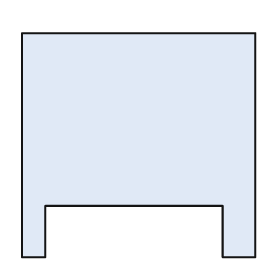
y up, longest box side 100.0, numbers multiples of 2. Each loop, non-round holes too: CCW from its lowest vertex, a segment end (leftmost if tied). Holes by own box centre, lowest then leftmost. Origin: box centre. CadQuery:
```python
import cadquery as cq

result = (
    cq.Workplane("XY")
    .moveTo(-50.0, -48.0)
    .lineTo(-40.0, -48.0)
    .lineTo(-40.0, -26.0)
    .lineTo(36.0, -26.0)
    .lineTo(36.0, -48.0)
    .lineTo(50.0, -48.0)
    .lineTo(50.0, 48.0)
    .lineTo(-50.0, 48.0)
    .close()
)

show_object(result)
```